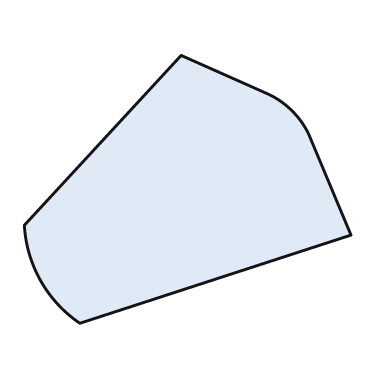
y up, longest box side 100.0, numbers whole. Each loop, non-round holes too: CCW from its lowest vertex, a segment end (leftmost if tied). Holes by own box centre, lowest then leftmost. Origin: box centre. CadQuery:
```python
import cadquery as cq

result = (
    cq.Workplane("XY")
    .moveTo(-33.0, -41.0)
    .lineTo(50.0, -14.0)
    .lineTo(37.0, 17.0)
    .threePointArc((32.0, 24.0), (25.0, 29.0))
    .lineTo(-2.0, 41.0)
    .lineTo(-50.0, -11.0)
    .threePointArc((-45.0, -28.0), (-33.0, -41.0))
    .close()
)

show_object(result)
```